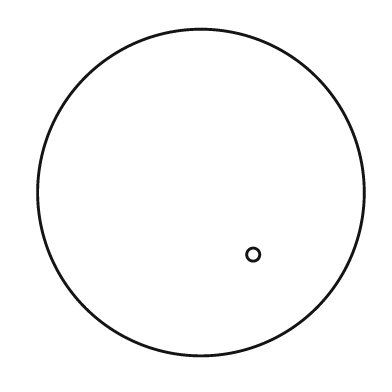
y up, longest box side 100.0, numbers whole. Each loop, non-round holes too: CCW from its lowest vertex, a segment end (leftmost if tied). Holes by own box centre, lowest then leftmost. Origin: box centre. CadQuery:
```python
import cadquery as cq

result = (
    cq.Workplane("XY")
    .moveTo(0.0, 0.0)
    .circle(50.0)
    .moveTo(16.0, -19.0)
    .circle(2.0)
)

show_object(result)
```